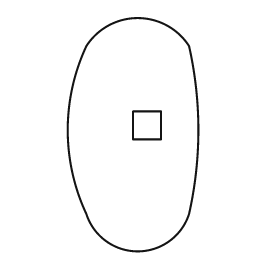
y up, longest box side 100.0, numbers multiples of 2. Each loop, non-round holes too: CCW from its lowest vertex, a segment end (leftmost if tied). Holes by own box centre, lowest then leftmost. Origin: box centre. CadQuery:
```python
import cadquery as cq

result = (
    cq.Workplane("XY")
    .moveTo(-20.0, -34.0)
    .threePointArc((2.0, -50.0), (24.0, -34.0))
    .threePointArc((28.0, 2.0), (24.0, 38.0))
    .threePointArc((2.0, 50.0), (-20.0, 38.0))
    .threePointArc((-28.0, 2.0), (-20.0, -34.0))
    .close()
    .moveTo(0.0, -2.0)
    .lineTo(12.0, -2.0)
    .lineTo(12.0, 10.0)
    .lineTo(0.0, 10.0)
    .close()
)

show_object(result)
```